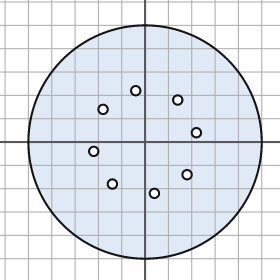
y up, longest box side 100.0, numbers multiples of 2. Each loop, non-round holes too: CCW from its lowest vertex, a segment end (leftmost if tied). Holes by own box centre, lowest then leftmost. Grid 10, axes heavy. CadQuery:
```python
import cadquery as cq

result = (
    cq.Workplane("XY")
    .moveTo(0.0, 0.0)
    .circle(50.0)
    .moveTo(4.0, -22.0)
    .circle(2.0)
    .moveTo(-14.0, -18.0)
    .circle(2.0)
    .moveTo(18.0, -14.0)
    .circle(2.0)
    .moveTo(-22.0, -4.0)
    .circle(2.0)
    .moveTo(22.0, 4.0)
    .circle(2.0)
    .moveTo(-18.0, 14.0)
    .circle(2.0)
    .moveTo(14.0, 18.0)
    .circle(2.0)
    .moveTo(-4.0, 22.0)
    .circle(2.0)
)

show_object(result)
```